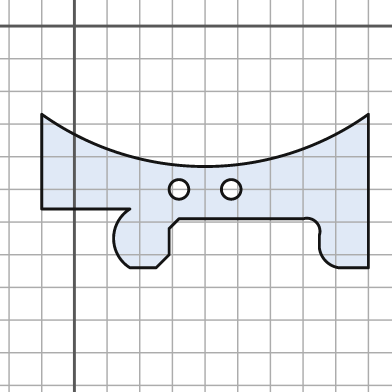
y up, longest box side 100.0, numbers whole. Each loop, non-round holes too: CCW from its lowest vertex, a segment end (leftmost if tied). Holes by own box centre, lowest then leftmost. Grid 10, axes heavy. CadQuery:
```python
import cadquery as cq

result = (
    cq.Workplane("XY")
    .moveTo(17.0, -74.0)
    .lineTo(25.0, -74.0)
    .lineTo(29.0, -70.0)
    .lineTo(29.0, -62.0)
    .lineTo(32.0, -59.0)
    .lineTo(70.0, -59.0)
    .threePointArc((74.0, -60.0), (75.0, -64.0))
    .lineTo(75.0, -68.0)
    .threePointArc((77.0, -72.0), (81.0, -74.0))
    .lineTo(90.0, -74.0)
    .lineTo(90.0, -27.0)
    .threePointArc((40.0, -43.0), (-10.0, -27.0))
    .lineTo(-10.0, -56.0)
    .lineTo(17.0, -56.0)
    .threePointArc((12.0, -65.0), (17.0, -74.0))
    .close()
    .moveTo(32.0, -50.0)
    .circle(3.0)
    .moveTo(48.0, -50.0)
    .circle(3.0)
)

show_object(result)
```